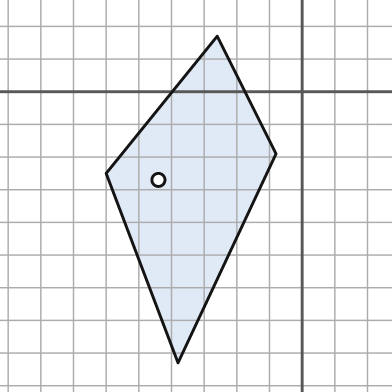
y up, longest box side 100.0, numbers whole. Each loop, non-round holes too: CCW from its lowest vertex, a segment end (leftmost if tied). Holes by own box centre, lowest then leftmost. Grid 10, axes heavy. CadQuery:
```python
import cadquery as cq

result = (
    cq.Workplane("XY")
    .moveTo(-38.0, -83.0)
    .lineTo(-8.0, -19.0)
    .lineTo(-26.0, 17.0)
    .lineTo(-60.0, -25.0)
    .close()
    .moveTo(-44.0, -27.0)
    .circle(2.0)
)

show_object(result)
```